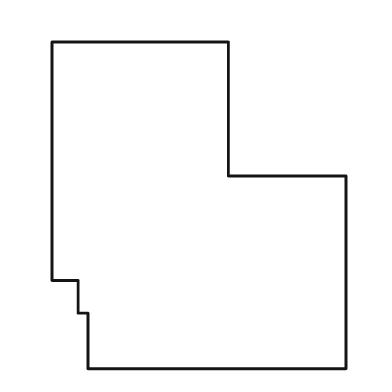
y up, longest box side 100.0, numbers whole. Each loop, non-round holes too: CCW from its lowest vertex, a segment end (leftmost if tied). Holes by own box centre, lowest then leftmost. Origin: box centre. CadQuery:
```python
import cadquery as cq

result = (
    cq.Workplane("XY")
    .moveTo(-34.0, -50.0)
    .lineTo(45.0, -50.0)
    .lineTo(45.0, 9.0)
    .lineTo(9.0, 9.0)
    .lineTo(9.0, 50.0)
    .lineTo(-45.0, 50.0)
    .lineTo(-45.0, -23.0)
    .lineTo(-37.0, -23.0)
    .lineTo(-37.0, -33.0)
    .lineTo(-34.0, -33.0)
    .close()
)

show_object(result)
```